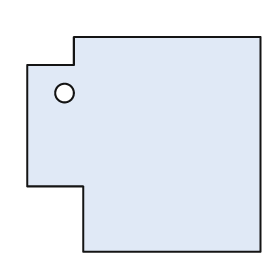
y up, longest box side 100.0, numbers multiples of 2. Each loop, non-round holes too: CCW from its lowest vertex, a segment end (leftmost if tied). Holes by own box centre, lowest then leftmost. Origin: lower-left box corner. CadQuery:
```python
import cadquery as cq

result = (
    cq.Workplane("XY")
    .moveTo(24.0, 0.0)
    .lineTo(100.0, 0.0)
    .lineTo(100.0, 92.0)
    .lineTo(20.0, 92.0)
    .lineTo(20.0, 80.0)
    .lineTo(0.0, 80.0)
    .lineTo(0.0, 28.0)
    .lineTo(24.0, 28.0)
    .close()
    .moveTo(16.0, 68.0)
    .circle(4.0)
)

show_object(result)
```